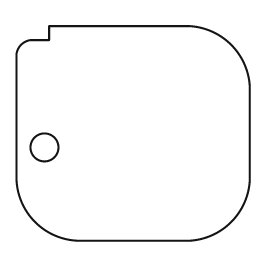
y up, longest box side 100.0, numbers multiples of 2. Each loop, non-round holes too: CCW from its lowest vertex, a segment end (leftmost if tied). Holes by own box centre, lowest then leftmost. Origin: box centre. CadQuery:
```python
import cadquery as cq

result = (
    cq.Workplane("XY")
    .moveTo(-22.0, -46.0)
    .lineTo(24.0, -46.0)
    .threePointArc((42.0, -38.0), (50.0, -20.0))
    .lineTo(50.0, 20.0)
    .threePointArc((42.0, 38.0), (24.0, 46.0))
    .lineTo(-36.0, 46.0)
    .lineTo(-36.0, 40.0)
    .lineTo(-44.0, 40.0)
    .threePointArc((-48.0, 38.0), (-50.0, 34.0))
    .lineTo(-50.0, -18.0)
    .threePointArc((-42.0, -38.0), (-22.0, -46.0))
    .close()
    .moveTo(-38.0, -6.0)
    .circle(6.0)
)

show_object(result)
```